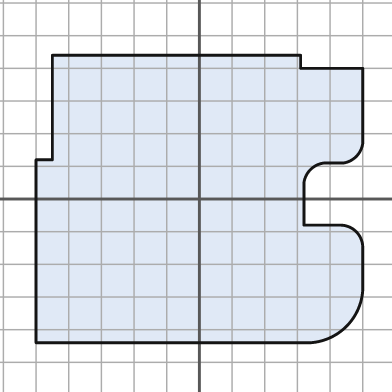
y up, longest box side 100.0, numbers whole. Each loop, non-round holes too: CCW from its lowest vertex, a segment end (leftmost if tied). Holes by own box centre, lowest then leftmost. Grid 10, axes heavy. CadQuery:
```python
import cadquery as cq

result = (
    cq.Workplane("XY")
    .moveTo(-50.0, -44.0)
    .lineTo(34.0, -44.0)
    .threePointArc((45.0, -39.0), (50.0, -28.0))
    .lineTo(50.0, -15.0)
    .threePointArc((48.0, -10.0), (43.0, -8.0))
    .lineTo(32.0, -8.0)
    .lineTo(32.0, 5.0)
    .threePointArc((34.0, 9.0), (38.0, 11.0))
    .lineTo(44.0, 11.0)
    .threePointArc((48.0, 13.0), (50.0, 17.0))
    .lineTo(50.0, 40.0)
    .lineTo(31.0, 40.0)
    .lineTo(31.0, 44.0)
    .lineTo(-45.0, 44.0)
    .lineTo(-45.0, 12.0)
    .lineTo(-50.0, 12.0)
    .close()
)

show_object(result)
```